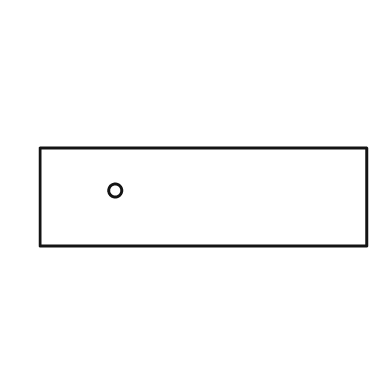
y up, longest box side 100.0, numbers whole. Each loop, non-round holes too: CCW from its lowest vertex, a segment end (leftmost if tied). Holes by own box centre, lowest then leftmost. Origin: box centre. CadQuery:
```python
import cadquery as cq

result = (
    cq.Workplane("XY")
    .moveTo(-50.0, -15.0)
    .lineTo(50.0, -15.0)
    .lineTo(50.0, 15.0)
    .lineTo(-50.0, 15.0)
    .close()
    .moveTo(-27.0, 2.0)
    .circle(2.0)
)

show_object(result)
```